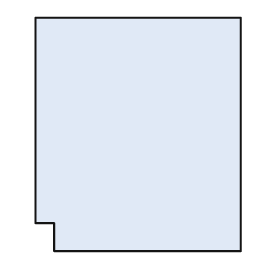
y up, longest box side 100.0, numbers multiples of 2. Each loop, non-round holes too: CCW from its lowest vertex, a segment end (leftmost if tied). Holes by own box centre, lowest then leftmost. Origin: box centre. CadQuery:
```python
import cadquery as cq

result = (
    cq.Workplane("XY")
    .moveTo(-36.0, -50.0)
    .lineTo(44.0, -50.0)
    .lineTo(44.0, 50.0)
    .lineTo(-44.0, 50.0)
    .lineTo(-44.0, -38.0)
    .lineTo(-36.0, -38.0)
    .close()
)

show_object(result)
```